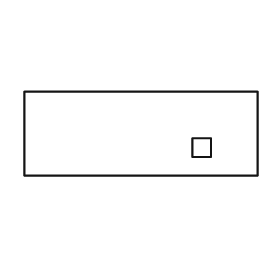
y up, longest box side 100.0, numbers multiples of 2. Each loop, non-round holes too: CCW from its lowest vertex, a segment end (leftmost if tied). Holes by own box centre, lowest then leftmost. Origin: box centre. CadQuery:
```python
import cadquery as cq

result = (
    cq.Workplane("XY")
    .moveTo(-50.0, -18.0)
    .lineTo(50.0, -18.0)
    .lineTo(50.0, 18.0)
    .lineTo(-50.0, 18.0)
    .close()
    .moveTo(22.0, -10.0)
    .lineTo(30.0, -10.0)
    .lineTo(30.0, -2.0)
    .lineTo(22.0, -2.0)
    .close()
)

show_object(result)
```